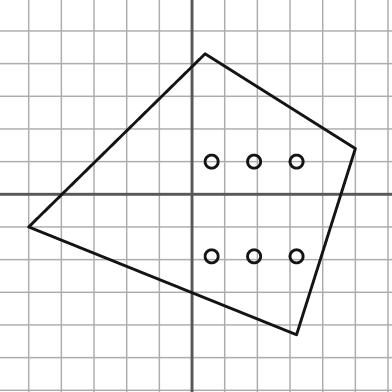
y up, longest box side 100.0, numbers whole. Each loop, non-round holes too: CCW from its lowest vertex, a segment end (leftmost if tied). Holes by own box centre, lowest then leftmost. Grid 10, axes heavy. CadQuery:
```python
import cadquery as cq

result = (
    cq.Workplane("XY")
    .moveTo(32.0, -43.0)
    .lineTo(50.0, 14.0)
    .lineTo(4.0, 43.0)
    .lineTo(-50.0, -10.0)
    .close()
    .moveTo(6.0, -19.0)
    .circle(2.0)
    .moveTo(19.0, -19.0)
    .circle(2.0)
    .moveTo(32.0, -19.0)
    .circle(2.0)
    .moveTo(6.0, 10.0)
    .circle(2.0)
    .moveTo(19.0, 10.0)
    .circle(2.0)
    .moveTo(32.0, 10.0)
    .circle(2.0)
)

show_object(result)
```